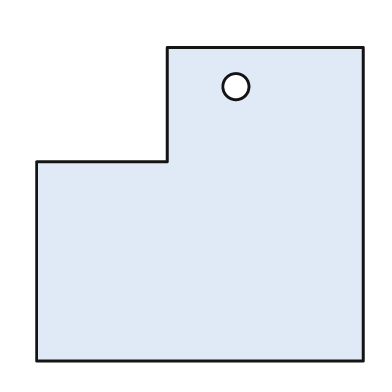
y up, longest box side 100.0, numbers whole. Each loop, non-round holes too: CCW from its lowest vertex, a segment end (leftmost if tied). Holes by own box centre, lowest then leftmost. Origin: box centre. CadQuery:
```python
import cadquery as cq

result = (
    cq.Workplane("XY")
    .moveTo(-50.0, -48.0)
    .lineTo(50.0, -48.0)
    .lineTo(50.0, 48.0)
    .lineTo(-10.0, 48.0)
    .lineTo(-10.0, 13.0)
    .lineTo(-50.0, 13.0)
    .close()
    .moveTo(11.0, 36.0)
    .circle(4.0)
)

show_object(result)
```